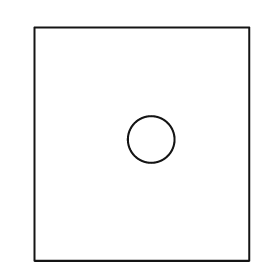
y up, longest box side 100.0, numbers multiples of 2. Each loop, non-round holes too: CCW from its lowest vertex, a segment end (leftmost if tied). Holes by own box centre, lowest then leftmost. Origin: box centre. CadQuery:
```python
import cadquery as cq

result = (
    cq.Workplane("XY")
    .moveTo(-46.0, -50.0)
    .lineTo(46.0, -50.0)
    .lineTo(46.0, 50.0)
    .lineTo(-46.0, 50.0)
    .close()
    .moveTo(4.0, 2.0)
    .circle(10.0)
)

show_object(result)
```